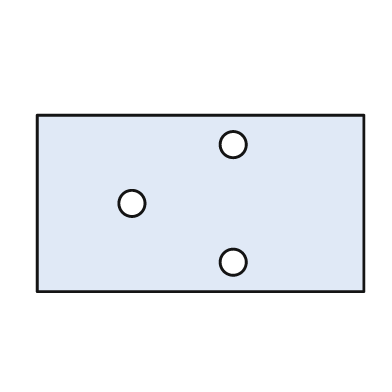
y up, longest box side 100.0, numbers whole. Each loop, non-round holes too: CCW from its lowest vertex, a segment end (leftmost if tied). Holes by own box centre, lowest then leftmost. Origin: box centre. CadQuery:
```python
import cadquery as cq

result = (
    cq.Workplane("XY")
    .moveTo(-50.0, -27.0)
    .lineTo(50.0, -27.0)
    .lineTo(50.0, 27.0)
    .lineTo(-50.0, 27.0)
    .close()
    .moveTo(10.0, -18.0)
    .circle(4.0)
    .moveTo(-21.0, 0.0)
    .circle(4.0)
    .moveTo(10.0, 18.0)
    .circle(4.0)
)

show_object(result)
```